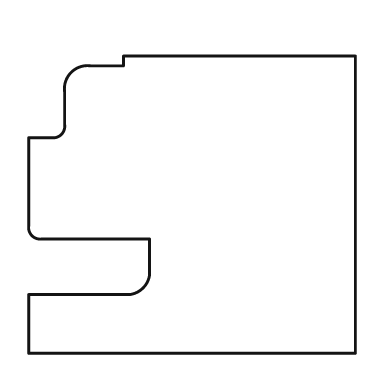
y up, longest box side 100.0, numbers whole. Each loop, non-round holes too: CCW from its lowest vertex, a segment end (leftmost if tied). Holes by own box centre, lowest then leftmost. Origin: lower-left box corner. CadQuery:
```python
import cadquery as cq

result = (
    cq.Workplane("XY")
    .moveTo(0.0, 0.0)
    .lineTo(100.0, 0.0)
    .lineTo(100.0, 91.0)
    .lineTo(29.0, 91.0)
    .lineTo(29.0, 88.0)
    .lineTo(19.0, 88.0)
    .threePointArc((13.0, 86.0), (11.0, 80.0))
    .lineTo(11.0, 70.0)
    .threePointArc((10.0, 67.0), (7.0, 66.0))
    .lineTo(0.0, 66.0)
    .lineTo(0.0, 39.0)
    .threePointArc((1.0, 36.0), (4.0, 35.0))
    .lineTo(37.0, 35.0)
    .lineTo(37.0, 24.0)
    .threePointArc((35.0, 20.0), (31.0, 18.0))
    .lineTo(0.0, 18.0)
    .close()
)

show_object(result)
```